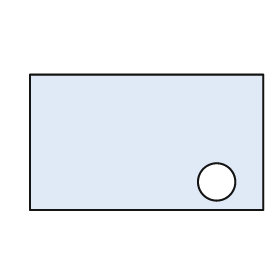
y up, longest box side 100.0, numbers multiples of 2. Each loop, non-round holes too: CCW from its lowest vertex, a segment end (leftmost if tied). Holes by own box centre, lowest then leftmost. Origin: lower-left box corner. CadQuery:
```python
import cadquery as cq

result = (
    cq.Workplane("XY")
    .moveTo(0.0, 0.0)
    .lineTo(100.0, 0.0)
    .lineTo(100.0, 58.0)
    .lineTo(0.0, 58.0)
    .close()
    .moveTo(80.0, 12.0)
    .circle(8.0)
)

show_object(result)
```